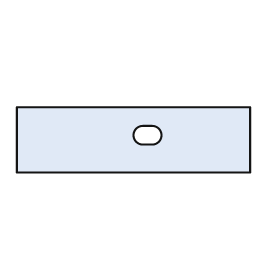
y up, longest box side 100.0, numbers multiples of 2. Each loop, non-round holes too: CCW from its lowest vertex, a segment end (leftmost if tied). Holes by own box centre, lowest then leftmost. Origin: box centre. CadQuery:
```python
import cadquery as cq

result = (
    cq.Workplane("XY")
    .moveTo(-50.0, -14.0)
    .lineTo(50.0, -14.0)
    .lineTo(50.0, 14.0)
    .lineTo(-50.0, 14.0)
    .close()
    .moveTo(4.0, -2.0)
    .lineTo(8.0, -2.0)
    .threePointArc((12.0, 2.0), (8.0, 6.0))
    .lineTo(4.0, 6.0)
    .threePointArc((0.0, 2.0), (4.0, -2.0))
    .close()
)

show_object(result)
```